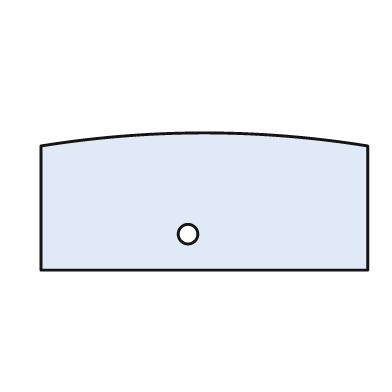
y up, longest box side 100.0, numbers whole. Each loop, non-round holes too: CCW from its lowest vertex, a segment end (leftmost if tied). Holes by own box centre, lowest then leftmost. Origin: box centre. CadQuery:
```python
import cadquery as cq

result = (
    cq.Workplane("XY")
    .moveTo(-50.0, -21.0)
    .lineTo(50.0, -21.0)
    .lineTo(50.0, 17.0)
    .threePointArc((0.0, 21.0), (-50.0, 17.0))
    .close()
    .moveTo(-5.0, -10.0)
    .circle(3.0)
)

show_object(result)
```